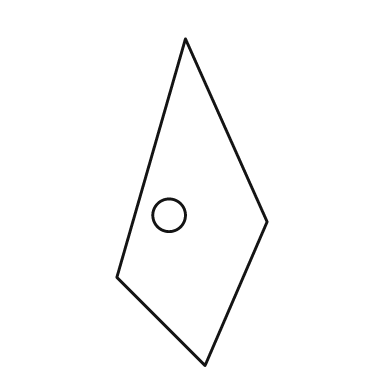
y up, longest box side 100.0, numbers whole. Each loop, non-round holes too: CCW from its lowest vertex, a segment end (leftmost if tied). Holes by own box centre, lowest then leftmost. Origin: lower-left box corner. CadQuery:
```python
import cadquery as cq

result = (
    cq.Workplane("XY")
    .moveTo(27.0, 0.0)
    .lineTo(46.0, 44.0)
    .lineTo(21.0, 100.0)
    .lineTo(0.0, 27.0)
    .close()
    .moveTo(16.0, 46.0)
    .circle(5.0)
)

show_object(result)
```